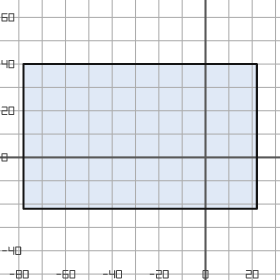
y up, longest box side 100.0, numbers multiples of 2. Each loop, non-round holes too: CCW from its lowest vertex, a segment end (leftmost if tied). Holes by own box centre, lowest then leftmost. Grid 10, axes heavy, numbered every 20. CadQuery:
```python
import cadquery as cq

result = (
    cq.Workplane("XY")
    .moveTo(-78.0, -22.0)
    .lineTo(22.0, -22.0)
    .lineTo(22.0, 40.0)
    .lineTo(-78.0, 40.0)
    .close()
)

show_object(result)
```